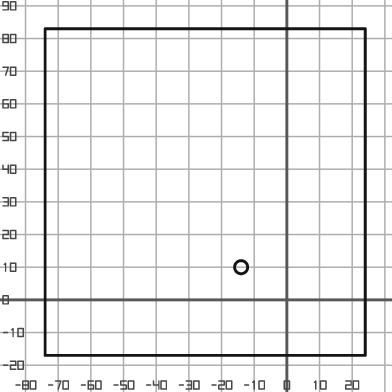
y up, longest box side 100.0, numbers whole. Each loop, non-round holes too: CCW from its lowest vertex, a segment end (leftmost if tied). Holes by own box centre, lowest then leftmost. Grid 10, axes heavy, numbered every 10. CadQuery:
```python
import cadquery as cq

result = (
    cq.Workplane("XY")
    .moveTo(-74.0, -17.0)
    .lineTo(24.0, -17.0)
    .lineTo(24.0, 83.0)
    .lineTo(-74.0, 83.0)
    .close()
    .moveTo(-14.0, 10.0)
    .circle(2.0)
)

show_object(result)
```